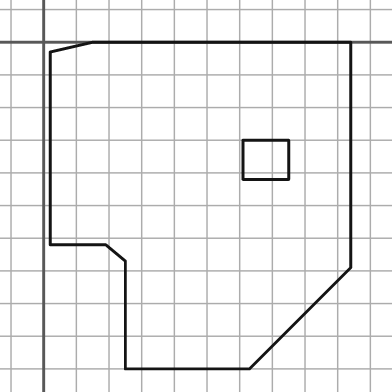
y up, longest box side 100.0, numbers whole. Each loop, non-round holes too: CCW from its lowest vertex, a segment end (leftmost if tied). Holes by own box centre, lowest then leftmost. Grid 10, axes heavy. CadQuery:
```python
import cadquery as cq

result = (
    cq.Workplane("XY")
    .moveTo(25.0, -100.0)
    .lineTo(63.0, -100.0)
    .lineTo(94.0, -69.0)
    .lineTo(94.0, 0.0)
    .lineTo(15.0, 0.0)
    .lineTo(2.0, -3.0)
    .lineTo(2.0, -62.0)
    .lineTo(19.0, -62.0)
    .lineTo(25.0, -67.0)
    .close()
    .moveTo(61.0, -42.0)
    .lineTo(75.0, -42.0)
    .lineTo(75.0, -30.0)
    .lineTo(61.0, -30.0)
    .close()
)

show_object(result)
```